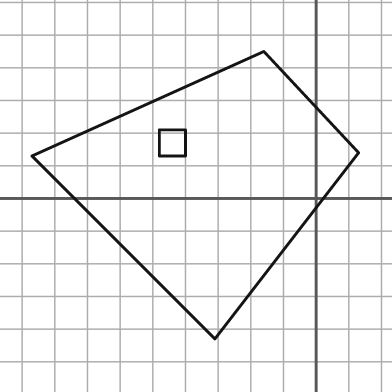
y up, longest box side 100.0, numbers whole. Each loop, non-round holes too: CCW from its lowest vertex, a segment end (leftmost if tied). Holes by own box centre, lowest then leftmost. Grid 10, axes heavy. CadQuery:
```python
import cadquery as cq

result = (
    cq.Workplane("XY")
    .moveTo(-31.0, -43.0)
    .lineTo(13.0, 14.0)
    .lineTo(-16.0, 45.0)
    .lineTo(-87.0, 13.0)
    .close()
    .moveTo(-48.0, 13.0)
    .lineTo(-40.0, 13.0)
    .lineTo(-40.0, 21.0)
    .lineTo(-48.0, 21.0)
    .close()
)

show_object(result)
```